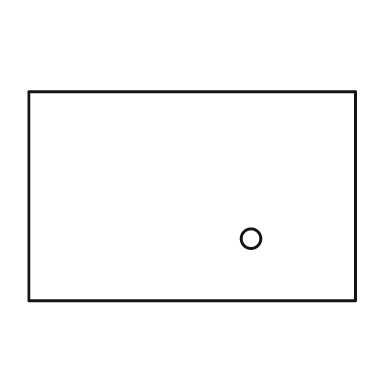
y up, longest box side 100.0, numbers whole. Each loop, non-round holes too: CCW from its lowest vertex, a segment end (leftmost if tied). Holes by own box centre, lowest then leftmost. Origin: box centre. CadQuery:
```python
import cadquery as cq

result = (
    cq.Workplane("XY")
    .moveTo(-50.0, -32.0)
    .lineTo(50.0, -32.0)
    .lineTo(50.0, 32.0)
    .lineTo(-50.0, 32.0)
    .close()
    .moveTo(18.0, -13.0)
    .circle(3.0)
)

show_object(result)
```